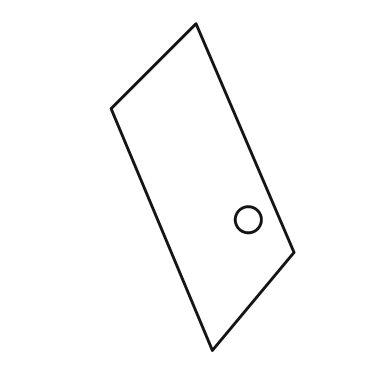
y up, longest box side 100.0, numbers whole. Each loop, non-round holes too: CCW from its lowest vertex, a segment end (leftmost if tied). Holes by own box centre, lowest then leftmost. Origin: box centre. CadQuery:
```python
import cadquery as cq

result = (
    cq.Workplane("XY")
    .moveTo(3.0, -50.0)
    .lineTo(28.0, -20.0)
    .lineTo(-2.0, 50.0)
    .lineTo(-28.0, 24.0)
    .close()
    .moveTo(14.0, -10.0)
    .circle(4.0)
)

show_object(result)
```